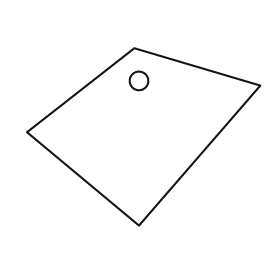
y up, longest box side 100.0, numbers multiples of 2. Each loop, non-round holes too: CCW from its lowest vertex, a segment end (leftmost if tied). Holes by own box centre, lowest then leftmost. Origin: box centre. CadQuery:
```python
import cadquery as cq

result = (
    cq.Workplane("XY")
    .moveTo(-2.0, -38.0)
    .lineTo(50.0, 22.0)
    .lineTo(-4.0, 38.0)
    .lineTo(-50.0, 2.0)
    .close()
    .moveTo(-2.0, 24.0)
    .circle(4.0)
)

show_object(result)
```